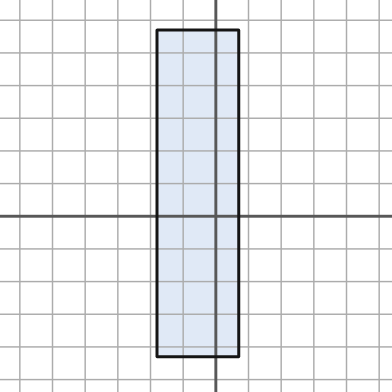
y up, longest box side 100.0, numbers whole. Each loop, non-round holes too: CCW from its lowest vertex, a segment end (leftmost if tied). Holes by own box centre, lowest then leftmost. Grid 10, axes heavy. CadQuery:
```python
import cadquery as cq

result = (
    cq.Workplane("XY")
    .moveTo(-18.0, -43.0)
    .lineTo(7.0, -43.0)
    .lineTo(7.0, 57.0)
    .lineTo(-18.0, 57.0)
    .close()
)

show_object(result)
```